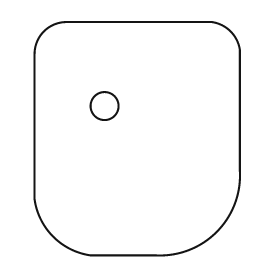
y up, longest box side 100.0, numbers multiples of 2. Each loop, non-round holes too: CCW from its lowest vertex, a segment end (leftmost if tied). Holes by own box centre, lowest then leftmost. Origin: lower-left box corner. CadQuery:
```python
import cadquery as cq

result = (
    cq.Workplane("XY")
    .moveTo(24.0, 0.0)
    .lineTo(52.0, 0.0)
    .threePointArc((78.0, 10.0), (88.0, 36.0))
    .lineTo(88.0, 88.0)
    .threePointArc((84.0, 96.0), (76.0, 100.0))
    .lineTo(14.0, 100.0)
    .threePointArc((4.0, 96.0), (0.0, 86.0))
    .lineTo(0.0, 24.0)
    .threePointArc((8.0, 8.0), (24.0, 0.0))
    .close()
    .moveTo(30.0, 64.0)
    .circle(6.0)
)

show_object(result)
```